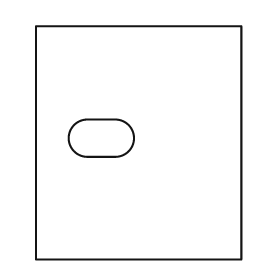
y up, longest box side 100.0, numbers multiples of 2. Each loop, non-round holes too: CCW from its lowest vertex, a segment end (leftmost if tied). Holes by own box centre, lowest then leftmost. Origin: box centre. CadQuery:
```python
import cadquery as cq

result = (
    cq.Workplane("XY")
    .moveTo(-44.0, -50.0)
    .lineTo(44.0, -50.0)
    .lineTo(44.0, 50.0)
    .lineTo(-44.0, 50.0)
    .close()
    .moveTo(-22.0, -6.0)
    .lineTo(-10.0, -6.0)
    .threePointArc((-2.0, 2.0), (-10.0, 10.0))
    .lineTo(-22.0, 10.0)
    .threePointArc((-30.0, 2.0), (-22.0, -6.0))
    .close()
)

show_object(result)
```